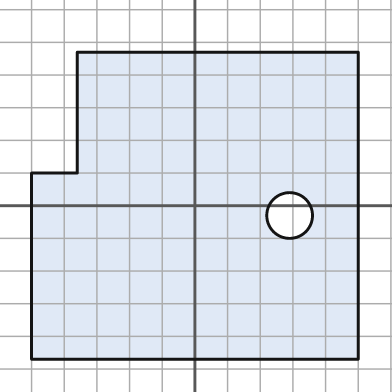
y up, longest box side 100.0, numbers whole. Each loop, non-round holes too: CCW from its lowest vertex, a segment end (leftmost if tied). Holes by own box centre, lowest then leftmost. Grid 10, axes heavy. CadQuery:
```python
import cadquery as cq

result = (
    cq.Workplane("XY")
    .moveTo(-50.0, -47.0)
    .lineTo(50.0, -47.0)
    .lineTo(50.0, 47.0)
    .lineTo(-36.0, 47.0)
    .lineTo(-36.0, 10.0)
    .lineTo(-50.0, 10.0)
    .close()
    .moveTo(29.0, -3.0)
    .circle(7.0)
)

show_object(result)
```